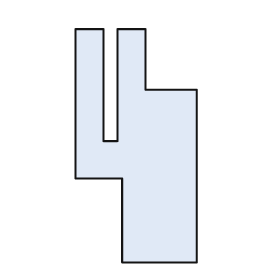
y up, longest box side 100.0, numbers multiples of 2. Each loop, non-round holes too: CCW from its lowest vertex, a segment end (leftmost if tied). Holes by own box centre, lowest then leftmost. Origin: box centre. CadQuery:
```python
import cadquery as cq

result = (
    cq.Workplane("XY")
    .moveTo(-6.0, -50.0)
    .lineTo(26.0, -50.0)
    .lineTo(26.0, 24.0)
    .lineTo(4.0, 24.0)
    .lineTo(4.0, 50.0)
    .lineTo(-8.0, 50.0)
    .lineTo(-8.0, 2.0)
    .lineTo(-14.0, 2.0)
    .lineTo(-14.0, 50.0)
    .lineTo(-26.0, 50.0)
    .lineTo(-26.0, -14.0)
    .lineTo(-6.0, -14.0)
    .close()
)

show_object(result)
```